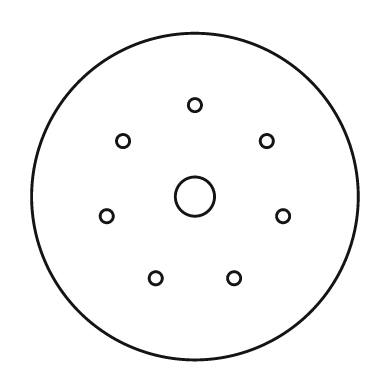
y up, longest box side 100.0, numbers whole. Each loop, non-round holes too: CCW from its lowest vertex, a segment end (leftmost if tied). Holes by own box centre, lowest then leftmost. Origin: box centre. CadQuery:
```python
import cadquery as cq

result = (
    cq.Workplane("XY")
    .moveTo(0.0, 0.0)
    .circle(50.0)
    .moveTo(-12.0, -25.0)
    .circle(2.0)
    .moveTo(12.0, -25.0)
    .circle(2.0)
    .moveTo(-27.0, -6.0)
    .circle(2.0)
    .moveTo(27.0, -6.0)
    .circle(2.0)
    .moveTo(0.0, 0.0)
    .circle(6.0)
    .moveTo(-22.0, 17.0)
    .circle(2.0)
    .moveTo(22.0, 17.0)
    .circle(2.0)
    .moveTo(0.0, 28.0)
    .circle(2.0)
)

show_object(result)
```